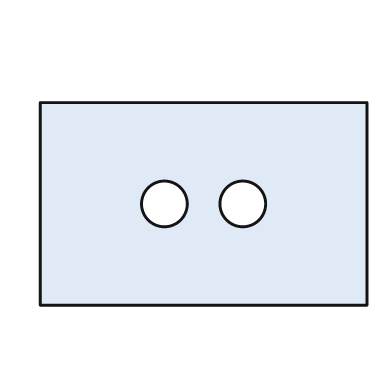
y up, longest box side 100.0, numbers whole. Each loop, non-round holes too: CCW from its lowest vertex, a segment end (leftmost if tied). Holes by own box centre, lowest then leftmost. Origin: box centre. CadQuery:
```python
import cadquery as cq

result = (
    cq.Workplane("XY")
    .moveTo(-50.0, -31.0)
    .lineTo(50.0, -31.0)
    .lineTo(50.0, 31.0)
    .lineTo(-50.0, 31.0)
    .close()
    .moveTo(-12.0, 0.0)
    .circle(7.0)
    .moveTo(12.0, 0.0)
    .circle(7.0)
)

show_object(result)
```